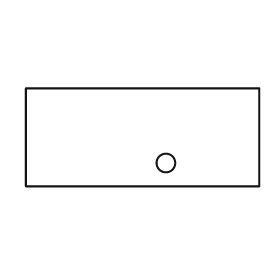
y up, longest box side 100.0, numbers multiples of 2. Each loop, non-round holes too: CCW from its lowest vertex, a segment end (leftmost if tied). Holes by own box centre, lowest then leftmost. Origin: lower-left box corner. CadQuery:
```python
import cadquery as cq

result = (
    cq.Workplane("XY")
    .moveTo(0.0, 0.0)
    .lineTo(100.0, 0.0)
    .lineTo(100.0, 42.0)
    .lineTo(0.0, 42.0)
    .close()
    .moveTo(60.0, 10.0)
    .circle(4.0)
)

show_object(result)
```